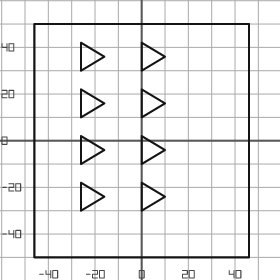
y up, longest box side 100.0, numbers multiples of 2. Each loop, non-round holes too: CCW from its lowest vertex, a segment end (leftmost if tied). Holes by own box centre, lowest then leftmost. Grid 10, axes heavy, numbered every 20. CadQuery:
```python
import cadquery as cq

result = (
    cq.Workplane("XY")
    .moveTo(-46.0, -50.0)
    .lineTo(46.0, -50.0)
    .lineTo(46.0, 50.0)
    .lineTo(-46.0, 50.0)
    .close()
    .moveTo(-26.0, -30.0)
    .lineTo(-16.0, -24.0)
    .lineTo(-26.0, -18.0)
    .close()
    .moveTo(0.0, -30.0)
    .lineTo(10.0, -24.0)
    .lineTo(0.0, -18.0)
    .close()
    .moveTo(-26.0, -10.0)
    .lineTo(-16.0, -4.0)
    .lineTo(-26.0, 2.0)
    .close()
    .moveTo(0.0, -10.0)
    .lineTo(10.0, -4.0)
    .lineTo(0.0, 2.0)
    .close()
    .moveTo(-26.0, 10.0)
    .lineTo(-16.0, 16.0)
    .lineTo(-26.0, 22.0)
    .close()
    .moveTo(0.0, 10.0)
    .lineTo(10.0, 16.0)
    .lineTo(0.0, 22.0)
    .close()
    .moveTo(-26.0, 30.0)
    .lineTo(-16.0, 36.0)
    .lineTo(-26.0, 42.0)
    .close()
    .moveTo(0.0, 30.0)
    .lineTo(10.0, 36.0)
    .lineTo(0.0, 42.0)
    .close()
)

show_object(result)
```